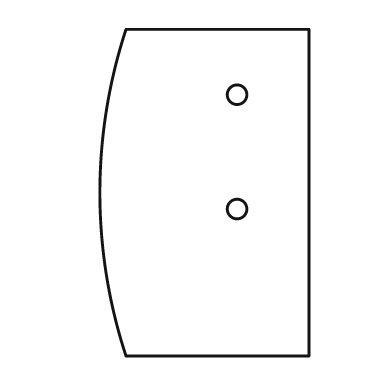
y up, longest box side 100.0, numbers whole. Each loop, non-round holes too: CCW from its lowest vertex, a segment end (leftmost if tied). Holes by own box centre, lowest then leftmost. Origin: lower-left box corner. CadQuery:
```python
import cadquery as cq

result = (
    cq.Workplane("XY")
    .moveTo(8.0, 0.0)
    .lineTo(64.0, 0.0)
    .lineTo(64.0, 100.0)
    .lineTo(8.0, 100.0)
    .threePointArc((0.0, 50.0), (8.0, 0.0))
    .close()
    .moveTo(42.0, 45.0)
    .circle(3.0)
    .moveTo(42.0, 80.0)
    .circle(3.0)
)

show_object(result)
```